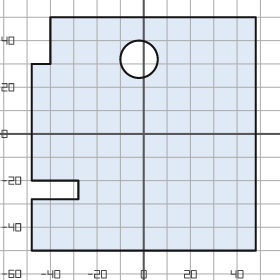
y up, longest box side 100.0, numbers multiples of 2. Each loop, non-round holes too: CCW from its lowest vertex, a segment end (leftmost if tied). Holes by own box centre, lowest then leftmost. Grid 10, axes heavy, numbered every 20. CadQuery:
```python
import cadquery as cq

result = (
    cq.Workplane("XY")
    .moveTo(-48.0, -50.0)
    .lineTo(48.0, -50.0)
    .lineTo(48.0, 50.0)
    .lineTo(-40.0, 50.0)
    .lineTo(-40.0, 30.0)
    .lineTo(-48.0, 30.0)
    .lineTo(-48.0, -20.0)
    .lineTo(-28.0, -20.0)
    .lineTo(-28.0, -28.0)
    .lineTo(-48.0, -28.0)
    .close()
    .moveTo(-2.0, 32.0)
    .circle(8.0)
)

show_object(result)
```